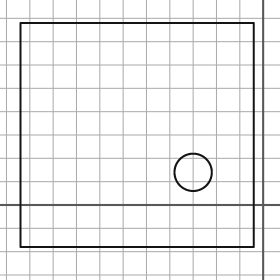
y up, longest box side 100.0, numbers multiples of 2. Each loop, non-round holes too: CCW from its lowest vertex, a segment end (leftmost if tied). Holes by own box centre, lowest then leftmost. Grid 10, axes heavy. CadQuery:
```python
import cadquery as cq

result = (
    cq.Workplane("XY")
    .moveTo(-104.0, -18.0)
    .lineTo(-4.0, -18.0)
    .lineTo(-4.0, 78.0)
    .lineTo(-104.0, 78.0)
    .close()
    .moveTo(-30.0, 14.0)
    .circle(8.0)
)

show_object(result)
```